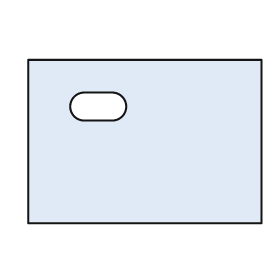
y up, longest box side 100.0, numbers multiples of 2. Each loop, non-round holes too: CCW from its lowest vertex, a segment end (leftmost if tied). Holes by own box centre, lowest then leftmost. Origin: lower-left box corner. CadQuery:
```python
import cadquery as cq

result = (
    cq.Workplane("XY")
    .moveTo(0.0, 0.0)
    .lineTo(100.0, 0.0)
    .lineTo(100.0, 70.0)
    .lineTo(0.0, 70.0)
    .close()
    .moveTo(24.0, 44.0)
    .lineTo(36.0, 44.0)
    .threePointArc((42.0, 50.0), (36.0, 56.0))
    .lineTo(24.0, 56.0)
    .threePointArc((18.0, 50.0), (24.0, 44.0))
    .close()
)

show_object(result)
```